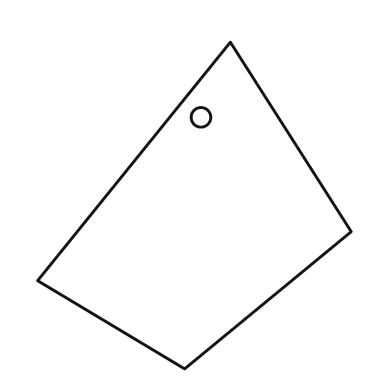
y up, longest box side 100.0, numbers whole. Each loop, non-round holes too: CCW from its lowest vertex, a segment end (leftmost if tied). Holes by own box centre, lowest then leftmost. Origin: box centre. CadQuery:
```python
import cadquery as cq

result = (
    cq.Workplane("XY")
    .moveTo(-3.0, -50.0)
    .lineTo(48.0, -8.0)
    .lineTo(11.0, 50.0)
    .lineTo(-48.0, -23.0)
    .close()
    .moveTo(2.0, 27.0)
    .circle(3.0)
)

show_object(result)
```